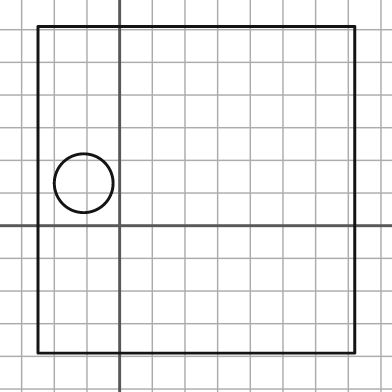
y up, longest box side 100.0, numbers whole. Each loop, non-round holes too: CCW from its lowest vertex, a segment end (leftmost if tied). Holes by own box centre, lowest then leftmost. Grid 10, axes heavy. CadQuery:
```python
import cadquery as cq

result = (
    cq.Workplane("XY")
    .moveTo(-25.0, -39.0)
    .lineTo(72.0, -39.0)
    .lineTo(72.0, 61.0)
    .lineTo(-25.0, 61.0)
    .close()
    .moveTo(-11.0, 13.0)
    .circle(9.0)
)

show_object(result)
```